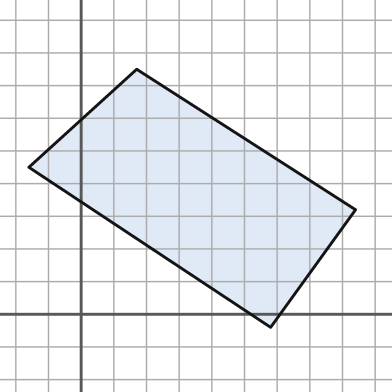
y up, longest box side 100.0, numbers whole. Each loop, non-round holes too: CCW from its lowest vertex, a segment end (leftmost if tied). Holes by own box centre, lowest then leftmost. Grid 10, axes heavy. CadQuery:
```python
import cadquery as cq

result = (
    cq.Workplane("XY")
    .moveTo(58.0, -4.0)
    .lineTo(84.0, 32.0)
    .lineTo(17.0, 75.0)
    .lineTo(-16.0, 45.0)
    .close()
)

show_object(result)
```